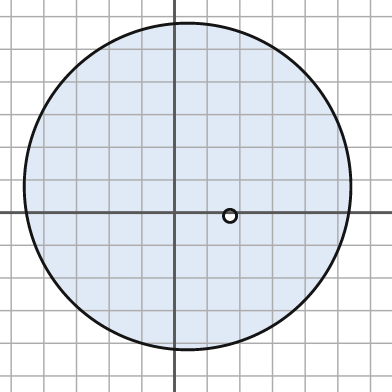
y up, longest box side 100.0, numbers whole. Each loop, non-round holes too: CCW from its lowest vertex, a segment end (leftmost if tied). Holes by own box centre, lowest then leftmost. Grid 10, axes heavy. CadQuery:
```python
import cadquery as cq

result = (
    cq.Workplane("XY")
    .moveTo(4.0, 8.0)
    .circle(50.0)
    .moveTo(17.0, -1.0)
    .circle(2.0)
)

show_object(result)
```